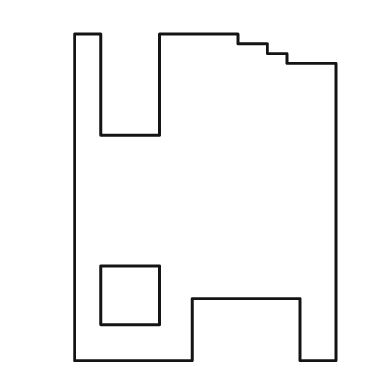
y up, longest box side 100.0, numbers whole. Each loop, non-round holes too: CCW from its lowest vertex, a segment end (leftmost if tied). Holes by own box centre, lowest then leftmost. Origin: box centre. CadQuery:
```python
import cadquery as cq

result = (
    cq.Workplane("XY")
    .moveTo(-40.0, -50.0)
    .lineTo(-4.0, -50.0)
    .lineTo(-4.0, -31.0)
    .lineTo(29.0, -31.0)
    .lineTo(29.0, -50.0)
    .lineTo(40.0, -50.0)
    .lineTo(40.0, 41.0)
    .lineTo(25.0, 41.0)
    .lineTo(25.0, 44.0)
    .lineTo(19.0, 44.0)
    .lineTo(19.0, 47.0)
    .lineTo(10.0, 47.0)
    .lineTo(10.0, 50.0)
    .lineTo(-14.0, 50.0)
    .lineTo(-14.0, 19.0)
    .lineTo(-32.0, 19.0)
    .lineTo(-32.0, 50.0)
    .lineTo(-40.0, 50.0)
    .close()
    .moveTo(-32.0, -39.0)
    .lineTo(-14.0, -39.0)
    .lineTo(-14.0, -21.0)
    .lineTo(-32.0, -21.0)
    .close()
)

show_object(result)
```